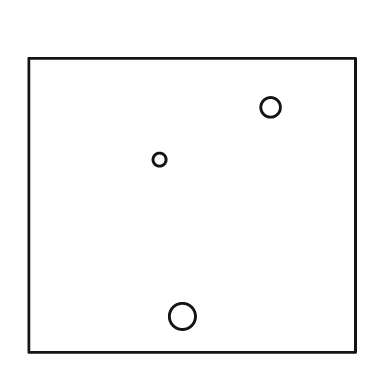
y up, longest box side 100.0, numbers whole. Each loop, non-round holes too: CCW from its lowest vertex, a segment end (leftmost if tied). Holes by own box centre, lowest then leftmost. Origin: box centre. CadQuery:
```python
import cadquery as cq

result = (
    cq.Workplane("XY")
    .moveTo(-50.0, -45.0)
    .lineTo(50.0, -45.0)
    .lineTo(50.0, 45.0)
    .lineTo(-50.0, 45.0)
    .close()
    .moveTo(-3.0, -34.0)
    .circle(4.0)
    .moveTo(-10.0, 14.0)
    .circle(2.0)
    .moveTo(24.0, 30.0)
    .circle(3.0)
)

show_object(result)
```